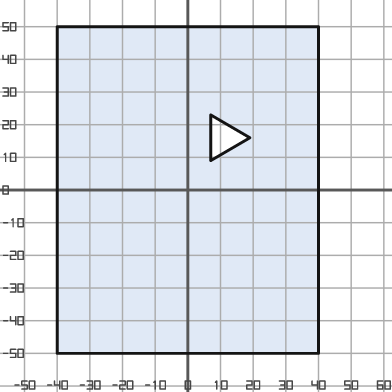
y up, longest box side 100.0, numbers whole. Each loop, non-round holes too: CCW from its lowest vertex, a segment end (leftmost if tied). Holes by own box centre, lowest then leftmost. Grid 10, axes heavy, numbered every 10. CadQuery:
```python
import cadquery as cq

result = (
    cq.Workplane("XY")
    .moveTo(-40.0, -50.0)
    .lineTo(40.0, -50.0)
    .lineTo(40.0, 50.0)
    .lineTo(-40.0, 50.0)
    .close()
    .moveTo(7.0, 9.0)
    .lineTo(19.0, 16.0)
    .lineTo(7.0, 23.0)
    .close()
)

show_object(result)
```